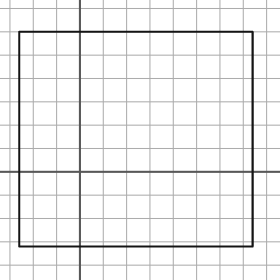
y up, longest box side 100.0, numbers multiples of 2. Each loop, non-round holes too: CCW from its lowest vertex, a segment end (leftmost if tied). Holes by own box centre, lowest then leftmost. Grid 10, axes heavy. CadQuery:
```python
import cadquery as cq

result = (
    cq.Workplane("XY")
    .moveTo(-26.0, -32.0)
    .lineTo(74.0, -32.0)
    .lineTo(74.0, 60.0)
    .lineTo(-26.0, 60.0)
    .close()
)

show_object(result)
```